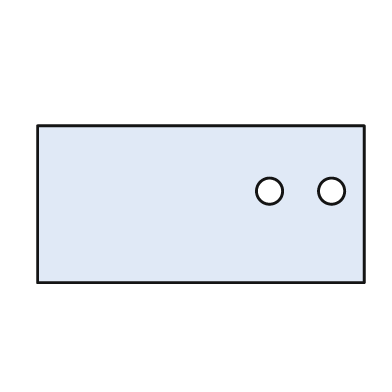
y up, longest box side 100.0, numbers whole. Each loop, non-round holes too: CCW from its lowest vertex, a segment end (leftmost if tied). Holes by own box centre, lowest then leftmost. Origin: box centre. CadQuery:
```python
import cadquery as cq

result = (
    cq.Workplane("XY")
    .moveTo(-50.0, -24.0)
    .lineTo(50.0, -24.0)
    .lineTo(50.0, 24.0)
    .lineTo(-50.0, 24.0)
    .close()
    .moveTo(21.0, 4.0)
    .circle(4.0)
    .moveTo(40.0, 4.0)
    .circle(4.0)
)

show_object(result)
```